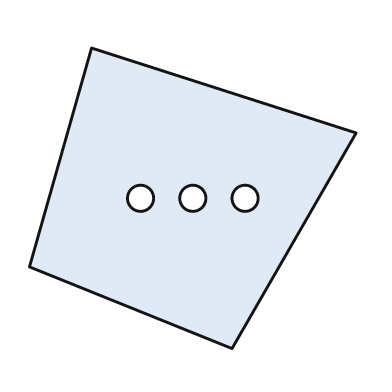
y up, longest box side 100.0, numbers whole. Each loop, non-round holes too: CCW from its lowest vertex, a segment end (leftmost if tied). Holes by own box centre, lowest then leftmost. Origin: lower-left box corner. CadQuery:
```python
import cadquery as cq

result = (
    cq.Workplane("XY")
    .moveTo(62.0, 0.0)
    .lineTo(100.0, 66.0)
    .lineTo(19.0, 92.0)
    .lineTo(0.0, 25.0)
    .close()
    .moveTo(34.0, 46.0)
    .circle(4.0)
    .moveTo(50.0, 46.0)
    .circle(4.0)
    .moveTo(66.0, 46.0)
    .circle(4.0)
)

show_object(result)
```